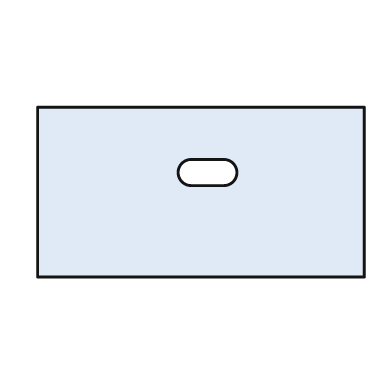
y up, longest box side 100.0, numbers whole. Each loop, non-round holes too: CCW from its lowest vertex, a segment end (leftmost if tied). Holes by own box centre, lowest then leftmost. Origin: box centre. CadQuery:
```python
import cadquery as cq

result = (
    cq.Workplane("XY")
    .moveTo(-50.0, -26.0)
    .lineTo(50.0, -26.0)
    .lineTo(50.0, 26.0)
    .lineTo(-50.0, 26.0)
    .close()
    .moveTo(-3.0, 2.0)
    .lineTo(7.0, 2.0)
    .threePointArc((11.0, 6.0), (7.0, 10.0))
    .lineTo(-3.0, 10.0)
    .threePointArc((-7.0, 6.0), (-3.0, 2.0))
    .close()
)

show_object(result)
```